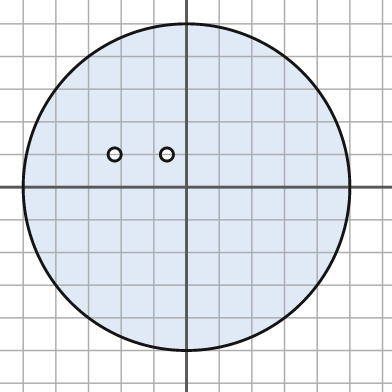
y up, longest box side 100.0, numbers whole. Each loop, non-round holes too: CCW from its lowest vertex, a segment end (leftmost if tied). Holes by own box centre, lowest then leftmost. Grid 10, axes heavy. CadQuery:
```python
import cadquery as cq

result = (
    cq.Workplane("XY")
    .moveTo(0.0, 0.0)
    .circle(50.0)
    .moveTo(-22.0, 10.0)
    .circle(2.0)
    .moveTo(-6.0, 10.0)
    .circle(2.0)
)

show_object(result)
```